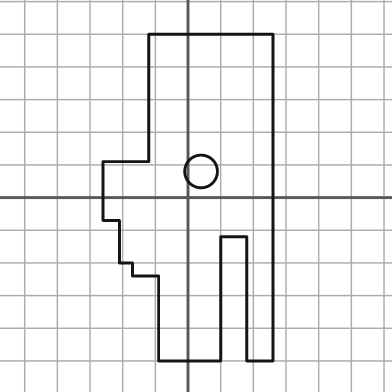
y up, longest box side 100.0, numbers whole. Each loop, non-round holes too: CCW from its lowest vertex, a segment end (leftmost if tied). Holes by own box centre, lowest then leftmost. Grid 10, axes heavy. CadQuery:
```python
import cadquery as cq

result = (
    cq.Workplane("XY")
    .moveTo(-9.0, -50.0)
    .lineTo(10.0, -50.0)
    .lineTo(10.0, -12.0)
    .lineTo(18.0, -12.0)
    .lineTo(18.0, -50.0)
    .lineTo(26.0, -50.0)
    .lineTo(26.0, 50.0)
    .lineTo(-12.0, 50.0)
    .lineTo(-12.0, 11.0)
    .lineTo(-26.0, 11.0)
    .lineTo(-26.0, -7.0)
    .lineTo(-21.0, -7.0)
    .lineTo(-21.0, -20.0)
    .lineTo(-17.0, -20.0)
    .lineTo(-17.0, -24.0)
    .lineTo(-9.0, -24.0)
    .close()
    .moveTo(4.0, 8.0)
    .circle(5.0)
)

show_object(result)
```